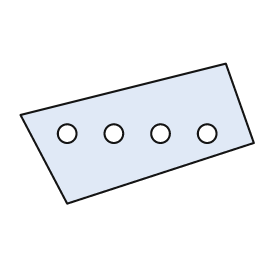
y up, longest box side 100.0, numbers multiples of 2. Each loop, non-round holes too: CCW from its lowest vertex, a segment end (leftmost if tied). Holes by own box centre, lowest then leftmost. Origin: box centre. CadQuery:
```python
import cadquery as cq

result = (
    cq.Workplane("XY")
    .moveTo(-30.0, -30.0)
    .lineTo(50.0, -4.0)
    .lineTo(38.0, 30.0)
    .lineTo(-50.0, 8.0)
    .close()
    .moveTo(-30.0, 0.0)
    .circle(4.0)
    .moveTo(-10.0, 0.0)
    .circle(4.0)
    .moveTo(10.0, 0.0)
    .circle(4.0)
    .moveTo(30.0, 0.0)
    .circle(4.0)
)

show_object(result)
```